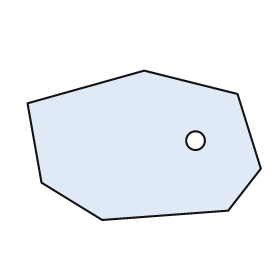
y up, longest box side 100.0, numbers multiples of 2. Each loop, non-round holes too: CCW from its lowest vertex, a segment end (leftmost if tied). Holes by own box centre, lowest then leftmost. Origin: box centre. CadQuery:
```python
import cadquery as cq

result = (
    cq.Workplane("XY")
    .moveTo(-18.0, -32.0)
    .lineTo(36.0, -28.0)
    .lineTo(50.0, -10.0)
    .lineTo(40.0, 22.0)
    .lineTo(0.0, 32.0)
    .lineTo(-50.0, 18.0)
    .lineTo(-44.0, -16.0)
    .close()
    .moveTo(22.0, 2.0)
    .circle(4.0)
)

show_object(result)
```